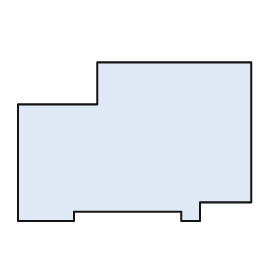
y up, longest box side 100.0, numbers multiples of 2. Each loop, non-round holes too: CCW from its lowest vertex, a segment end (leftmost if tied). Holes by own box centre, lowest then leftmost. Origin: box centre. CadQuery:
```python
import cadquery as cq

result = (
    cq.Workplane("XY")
    .moveTo(-50.0, -34.0)
    .lineTo(-26.0, -34.0)
    .lineTo(-26.0, -30.0)
    .lineTo(20.0, -30.0)
    .lineTo(20.0, -34.0)
    .lineTo(28.0, -34.0)
    .lineTo(28.0, -26.0)
    .lineTo(50.0, -26.0)
    .lineTo(50.0, 34.0)
    .lineTo(-16.0, 34.0)
    .lineTo(-16.0, 16.0)
    .lineTo(-50.0, 16.0)
    .close()
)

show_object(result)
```